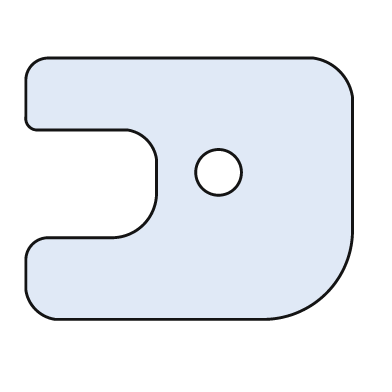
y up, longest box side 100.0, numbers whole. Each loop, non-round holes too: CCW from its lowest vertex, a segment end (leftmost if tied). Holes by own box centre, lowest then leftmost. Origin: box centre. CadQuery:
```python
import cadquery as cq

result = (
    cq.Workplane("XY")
    .moveTo(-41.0, -40.0)
    .lineTo(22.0, -40.0)
    .threePointArc((42.0, -32.0), (50.0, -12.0))
    .lineTo(50.0, 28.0)
    .threePointArc((46.0, 36.0), (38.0, 40.0))
    .lineTo(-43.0, 40.0)
    .threePointArc((-48.0, 38.0), (-50.0, 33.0))
    .lineTo(-50.0, 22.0)
    .threePointArc((-49.0, 19.0), (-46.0, 18.0))
    .lineTo(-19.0, 18.0)
    .threePointArc((-13.0, 15.0), (-10.0, 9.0))
    .lineTo(-10.0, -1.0)
    .threePointArc((-14.0, -11.0), (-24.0, -15.0))
    .lineTo(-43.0, -15.0)
    .threePointArc((-48.0, -17.0), (-50.0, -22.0))
    .lineTo(-50.0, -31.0)
    .threePointArc((-47.0, -37.0), (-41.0, -40.0))
    .close()
    .moveTo(9.0, 5.0)
    .circle(7.0)
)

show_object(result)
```